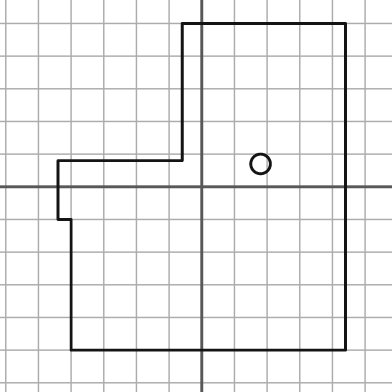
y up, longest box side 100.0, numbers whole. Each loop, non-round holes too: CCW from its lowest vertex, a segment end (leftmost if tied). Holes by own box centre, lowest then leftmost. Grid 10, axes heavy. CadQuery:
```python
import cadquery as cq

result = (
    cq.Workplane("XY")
    .moveTo(-40.0, -50.0)
    .lineTo(44.0, -50.0)
    .lineTo(44.0, 50.0)
    .lineTo(-6.0, 50.0)
    .lineTo(-6.0, 8.0)
    .lineTo(-44.0, 8.0)
    .lineTo(-44.0, -10.0)
    .lineTo(-40.0, -10.0)
    .close()
    .moveTo(18.0, 7.0)
    .circle(3.0)
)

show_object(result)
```